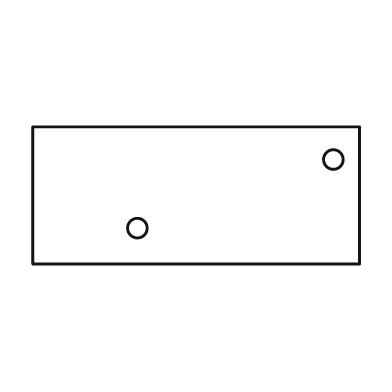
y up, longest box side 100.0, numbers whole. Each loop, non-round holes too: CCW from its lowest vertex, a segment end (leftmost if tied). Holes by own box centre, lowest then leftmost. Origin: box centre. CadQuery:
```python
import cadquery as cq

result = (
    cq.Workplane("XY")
    .moveTo(-50.0, -21.0)
    .lineTo(50.0, -21.0)
    .lineTo(50.0, 21.0)
    .lineTo(-50.0, 21.0)
    .close()
    .moveTo(-18.0, -10.0)
    .circle(3.0)
    .moveTo(42.0, 11.0)
    .circle(3.0)
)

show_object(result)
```